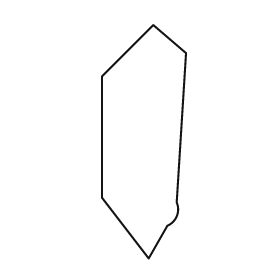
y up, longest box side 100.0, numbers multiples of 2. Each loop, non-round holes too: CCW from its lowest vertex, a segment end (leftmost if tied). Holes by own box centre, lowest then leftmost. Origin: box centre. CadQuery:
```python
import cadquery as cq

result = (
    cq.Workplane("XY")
    .moveTo(2.0, -50.0)
    .lineTo(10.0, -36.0)
    .threePointArc((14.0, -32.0), (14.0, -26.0))
    .lineTo(18.0, 38.0)
    .lineTo(4.0, 50.0)
    .lineTo(-18.0, 28.0)
    .lineTo(-18.0, -24.0)
    .close()
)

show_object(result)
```